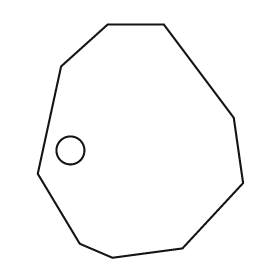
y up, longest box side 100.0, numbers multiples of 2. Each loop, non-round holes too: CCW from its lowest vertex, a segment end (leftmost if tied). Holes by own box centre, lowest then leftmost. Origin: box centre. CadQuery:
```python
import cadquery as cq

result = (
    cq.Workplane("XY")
    .moveTo(-12.0, -50.0)
    .lineTo(18.0, -46.0)
    .lineTo(44.0, -18.0)
    .lineTo(40.0, 10.0)
    .lineTo(10.0, 50.0)
    .lineTo(-14.0, 50.0)
    .lineTo(-34.0, 32.0)
    .lineTo(-44.0, -14.0)
    .lineTo(-26.0, -44.0)
    .close()
    .moveTo(-30.0, -4.0)
    .circle(6.0)
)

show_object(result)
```